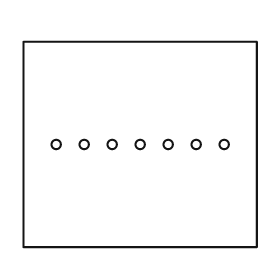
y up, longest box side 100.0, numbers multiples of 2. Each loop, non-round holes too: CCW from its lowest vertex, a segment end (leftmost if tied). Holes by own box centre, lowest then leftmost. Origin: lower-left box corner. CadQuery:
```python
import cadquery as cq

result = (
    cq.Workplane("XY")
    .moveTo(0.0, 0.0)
    .lineTo(100.0, 0.0)
    .lineTo(100.0, 88.0)
    .lineTo(0.0, 88.0)
    .close()
    .moveTo(14.0, 44.0)
    .circle(2.0)
    .moveTo(26.0, 44.0)
    .circle(2.0)
    .moveTo(38.0, 44.0)
    .circle(2.0)
    .moveTo(50.0, 44.0)
    .circle(2.0)
    .moveTo(62.0, 44.0)
    .circle(2.0)
    .moveTo(74.0, 44.0)
    .circle(2.0)
    .moveTo(86.0, 44.0)
    .circle(2.0)
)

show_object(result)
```